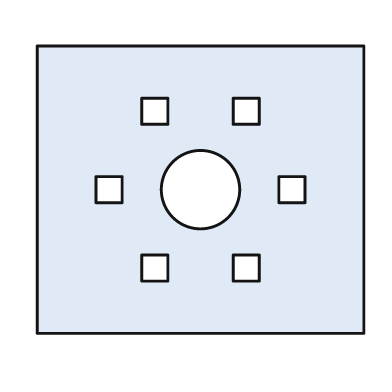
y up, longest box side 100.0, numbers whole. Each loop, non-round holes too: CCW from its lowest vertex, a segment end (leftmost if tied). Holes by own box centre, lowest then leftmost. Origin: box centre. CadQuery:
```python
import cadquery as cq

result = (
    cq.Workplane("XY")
    .moveTo(-50.0, -44.0)
    .lineTo(50.0, -44.0)
    .lineTo(50.0, 44.0)
    .lineTo(-50.0, 44.0)
    .close()
    .moveTo(-18.0, -28.0)
    .lineTo(-10.0, -28.0)
    .lineTo(-10.0, -20.0)
    .lineTo(-18.0, -20.0)
    .close()
    .moveTo(10.0, -28.0)
    .lineTo(18.0, -28.0)
    .lineTo(18.0, -20.0)
    .lineTo(10.0, -20.0)
    .close()
    .moveTo(-32.0, -4.0)
    .lineTo(-24.0, -4.0)
    .lineTo(-24.0, 4.0)
    .lineTo(-32.0, 4.0)
    .close()
    .moveTo(0.0, 0.0)
    .circle(12.0)
    .moveTo(24.0, -4.0)
    .lineTo(32.0, -4.0)
    .lineTo(32.0, 4.0)
    .lineTo(24.0, 4.0)
    .close()
    .moveTo(-18.0, 20.0)
    .lineTo(-10.0, 20.0)
    .lineTo(-10.0, 28.0)
    .lineTo(-18.0, 28.0)
    .close()
    .moveTo(10.0, 20.0)
    .lineTo(18.0, 20.0)
    .lineTo(18.0, 28.0)
    .lineTo(10.0, 28.0)
    .close()
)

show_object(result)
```